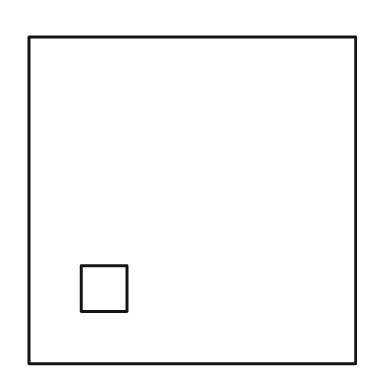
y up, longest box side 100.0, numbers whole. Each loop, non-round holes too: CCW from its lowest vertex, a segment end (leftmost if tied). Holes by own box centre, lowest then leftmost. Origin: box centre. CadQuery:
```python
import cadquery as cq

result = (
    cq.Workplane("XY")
    .moveTo(-50.0, -50.0)
    .lineTo(50.0, -50.0)
    .lineTo(50.0, 50.0)
    .lineTo(-50.0, 50.0)
    .close()
    .moveTo(-34.0, -34.0)
    .lineTo(-20.0, -34.0)
    .lineTo(-20.0, -20.0)
    .lineTo(-34.0, -20.0)
    .close()
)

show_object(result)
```